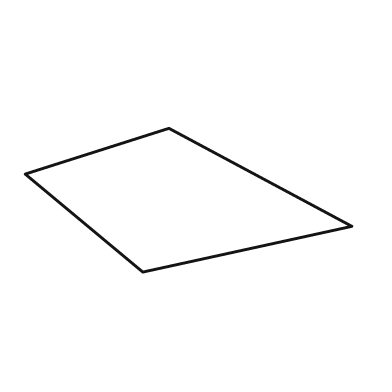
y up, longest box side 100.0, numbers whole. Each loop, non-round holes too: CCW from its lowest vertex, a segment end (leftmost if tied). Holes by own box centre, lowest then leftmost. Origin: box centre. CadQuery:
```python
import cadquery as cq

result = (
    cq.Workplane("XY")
    .moveTo(-14.0, -22.0)
    .lineTo(50.0, -8.0)
    .lineTo(-6.0, 22.0)
    .lineTo(-50.0, 8.0)
    .close()
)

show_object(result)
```